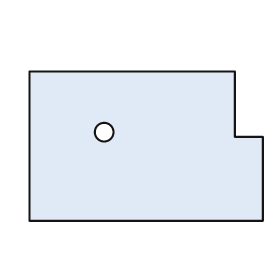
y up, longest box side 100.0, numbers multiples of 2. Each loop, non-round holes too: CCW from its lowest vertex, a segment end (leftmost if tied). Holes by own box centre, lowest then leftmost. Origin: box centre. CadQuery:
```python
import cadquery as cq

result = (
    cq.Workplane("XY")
    .moveTo(-50.0, -32.0)
    .lineTo(50.0, -32.0)
    .lineTo(50.0, 4.0)
    .lineTo(38.0, 4.0)
    .lineTo(38.0, 32.0)
    .lineTo(-50.0, 32.0)
    .close()
    .moveTo(-18.0, 6.0)
    .circle(4.0)
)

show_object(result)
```